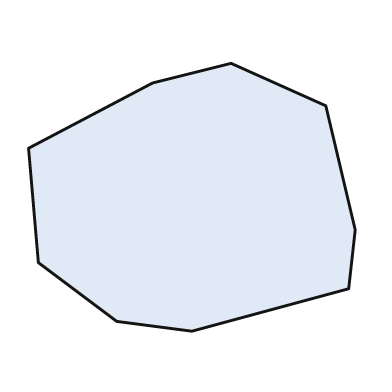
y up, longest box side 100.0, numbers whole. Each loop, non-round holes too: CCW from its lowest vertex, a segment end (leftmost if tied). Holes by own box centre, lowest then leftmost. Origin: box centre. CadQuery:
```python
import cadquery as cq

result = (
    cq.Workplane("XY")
    .moveTo(0.0, -41.0)
    .lineTo(48.0, -28.0)
    .lineTo(50.0, -10.0)
    .lineTo(41.0, 28.0)
    .lineTo(12.0, 41.0)
    .lineTo(-12.0, 35.0)
    .lineTo(-50.0, 15.0)
    .lineTo(-47.0, -20.0)
    .lineTo(-23.0, -38.0)
    .close()
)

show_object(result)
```